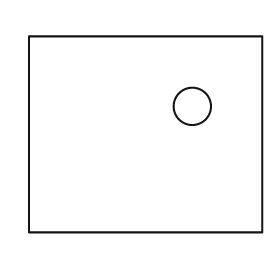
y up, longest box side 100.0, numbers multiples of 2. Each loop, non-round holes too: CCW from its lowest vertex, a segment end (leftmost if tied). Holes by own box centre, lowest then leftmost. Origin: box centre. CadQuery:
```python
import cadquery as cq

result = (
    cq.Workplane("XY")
    .moveTo(-50.0, -42.0)
    .lineTo(50.0, -42.0)
    .lineTo(50.0, 42.0)
    .lineTo(-50.0, 42.0)
    .close()
    .moveTo(20.0, 12.0)
    .circle(8.0)
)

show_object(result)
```